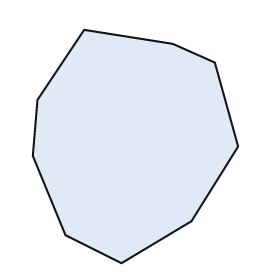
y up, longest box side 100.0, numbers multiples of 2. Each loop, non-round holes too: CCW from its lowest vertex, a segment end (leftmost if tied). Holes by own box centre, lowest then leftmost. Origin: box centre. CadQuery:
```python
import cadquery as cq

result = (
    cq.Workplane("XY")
    .moveTo(-6.0, -50.0)
    .lineTo(24.0, -32.0)
    .lineTo(44.0, 0.0)
    .lineTo(34.0, 36.0)
    .lineTo(16.0, 44.0)
    .lineTo(-22.0, 50.0)
    .lineTo(-42.0, 20.0)
    .lineTo(-44.0, -4.0)
    .lineTo(-30.0, -38.0)
    .close()
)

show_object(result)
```